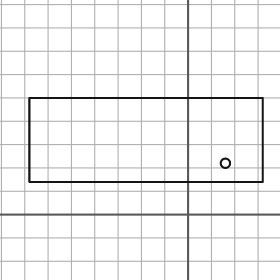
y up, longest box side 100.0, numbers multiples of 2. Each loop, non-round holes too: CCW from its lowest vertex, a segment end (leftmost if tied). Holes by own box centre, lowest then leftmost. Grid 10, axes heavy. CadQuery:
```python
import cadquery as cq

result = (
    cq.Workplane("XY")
    .moveTo(-68.0, 14.0)
    .lineTo(32.0, 14.0)
    .lineTo(32.0, 50.0)
    .lineTo(-68.0, 50.0)
    .close()
    .moveTo(16.0, 22.0)
    .circle(2.0)
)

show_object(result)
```